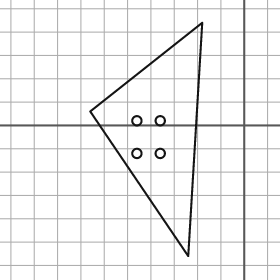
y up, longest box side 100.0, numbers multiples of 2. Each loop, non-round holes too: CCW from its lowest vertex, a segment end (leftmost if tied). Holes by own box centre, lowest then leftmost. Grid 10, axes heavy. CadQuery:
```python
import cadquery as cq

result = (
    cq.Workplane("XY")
    .moveTo(-24.0, -56.0)
    .lineTo(-18.0, 44.0)
    .lineTo(-66.0, 6.0)
    .close()
    .moveTo(-46.0, -12.0)
    .circle(2.0)
    .moveTo(-36.0, -12.0)
    .circle(2.0)
    .moveTo(-46.0, 2.0)
    .circle(2.0)
    .moveTo(-36.0, 2.0)
    .circle(2.0)
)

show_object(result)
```